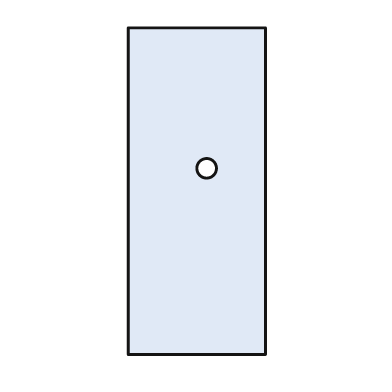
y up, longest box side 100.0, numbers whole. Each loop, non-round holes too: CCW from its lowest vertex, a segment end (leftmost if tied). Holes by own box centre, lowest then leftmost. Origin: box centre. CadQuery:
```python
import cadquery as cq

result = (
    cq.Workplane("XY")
    .moveTo(-21.0, -50.0)
    .lineTo(21.0, -50.0)
    .lineTo(21.0, 50.0)
    .lineTo(-21.0, 50.0)
    .close()
    .moveTo(3.0, 7.0)
    .circle(3.0)
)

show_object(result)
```